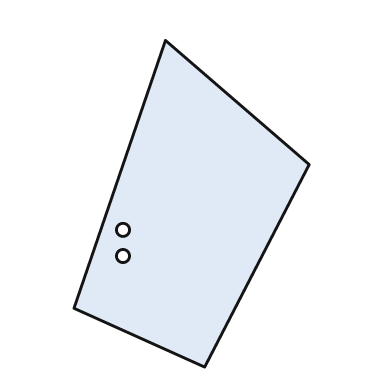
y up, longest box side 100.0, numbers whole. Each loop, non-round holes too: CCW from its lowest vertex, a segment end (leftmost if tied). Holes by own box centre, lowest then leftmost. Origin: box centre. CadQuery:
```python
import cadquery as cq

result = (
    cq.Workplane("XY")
    .moveTo(4.0, -50.0)
    .lineTo(36.0, 12.0)
    .lineTo(-8.0, 50.0)
    .lineTo(-36.0, -32.0)
    .close()
    .moveTo(-21.0, -16.0)
    .circle(2.0)
    .moveTo(-21.0, -8.0)
    .circle(2.0)
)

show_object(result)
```